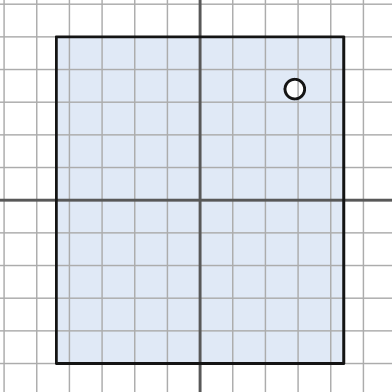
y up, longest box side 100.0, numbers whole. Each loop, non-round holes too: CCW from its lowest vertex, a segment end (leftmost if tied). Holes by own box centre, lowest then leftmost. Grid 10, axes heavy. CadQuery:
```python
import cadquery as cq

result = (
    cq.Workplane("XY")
    .moveTo(-44.0, -50.0)
    .lineTo(44.0, -50.0)
    .lineTo(44.0, 50.0)
    .lineTo(-44.0, 50.0)
    .close()
    .moveTo(29.0, 34.0)
    .circle(3.0)
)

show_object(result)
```